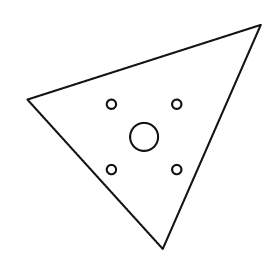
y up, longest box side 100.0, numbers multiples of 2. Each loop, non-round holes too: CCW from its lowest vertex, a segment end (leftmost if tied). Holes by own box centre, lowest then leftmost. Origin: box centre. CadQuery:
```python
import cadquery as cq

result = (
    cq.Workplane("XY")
    .moveTo(8.0, -48.0)
    .lineTo(50.0, 48.0)
    .lineTo(-50.0, 16.0)
    .close()
    .moveTo(-14.0, -14.0)
    .circle(2.0)
    .moveTo(14.0, -14.0)
    .circle(2.0)
    .moveTo(0.0, 0.0)
    .circle(6.0)
    .moveTo(-14.0, 14.0)
    .circle(2.0)
    .moveTo(14.0, 14.0)
    .circle(2.0)
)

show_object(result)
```